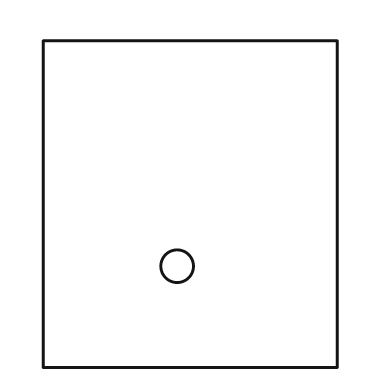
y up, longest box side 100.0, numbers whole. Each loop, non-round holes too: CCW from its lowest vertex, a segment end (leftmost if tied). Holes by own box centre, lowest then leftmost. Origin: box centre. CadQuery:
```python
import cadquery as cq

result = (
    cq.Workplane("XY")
    .moveTo(-45.0, -50.0)
    .lineTo(45.0, -50.0)
    .lineTo(45.0, 50.0)
    .lineTo(-45.0, 50.0)
    .close()
    .moveTo(-4.0, -19.0)
    .circle(5.0)
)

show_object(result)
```